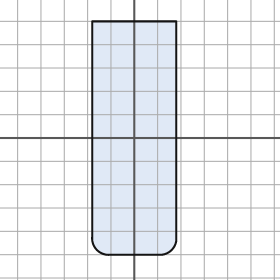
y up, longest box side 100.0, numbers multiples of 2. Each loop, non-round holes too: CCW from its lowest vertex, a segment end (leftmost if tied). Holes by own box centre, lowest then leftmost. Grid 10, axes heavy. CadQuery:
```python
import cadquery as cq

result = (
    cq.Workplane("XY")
    .moveTo(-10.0, -50.0)
    .lineTo(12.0, -50.0)
    .threePointArc((16.0, -48.0), (18.0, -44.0))
    .lineTo(18.0, 50.0)
    .lineTo(-18.0, 50.0)
    .lineTo(-18.0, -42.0)
    .threePointArc((-16.0, -48.0), (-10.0, -50.0))
    .close()
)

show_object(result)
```